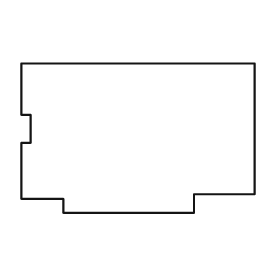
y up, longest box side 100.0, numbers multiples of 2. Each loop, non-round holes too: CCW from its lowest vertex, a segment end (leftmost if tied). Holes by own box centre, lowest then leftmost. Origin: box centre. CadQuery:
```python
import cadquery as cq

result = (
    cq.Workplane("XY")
    .moveTo(-32.0, -32.0)
    .lineTo(24.0, -32.0)
    .lineTo(24.0, -24.0)
    .lineTo(50.0, -24.0)
    .lineTo(50.0, 32.0)
    .lineTo(-50.0, 32.0)
    .lineTo(-50.0, 10.0)
    .lineTo(-46.0, 10.0)
    .lineTo(-46.0, -2.0)
    .lineTo(-50.0, -2.0)
    .lineTo(-50.0, -26.0)
    .lineTo(-32.0, -26.0)
    .close()
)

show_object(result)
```